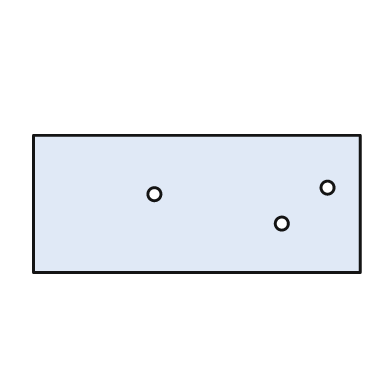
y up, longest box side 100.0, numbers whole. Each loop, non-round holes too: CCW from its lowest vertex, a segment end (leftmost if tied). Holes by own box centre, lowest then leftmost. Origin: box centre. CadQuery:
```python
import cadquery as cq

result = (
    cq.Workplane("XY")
    .moveTo(-50.0, -21.0)
    .lineTo(50.0, -21.0)
    .lineTo(50.0, 21.0)
    .lineTo(-50.0, 21.0)
    .close()
    .moveTo(26.0, -6.0)
    .circle(2.0)
    .moveTo(-13.0, 3.0)
    .circle(2.0)
    .moveTo(40.0, 5.0)
    .circle(2.0)
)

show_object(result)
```